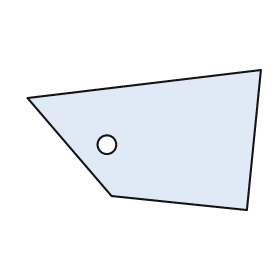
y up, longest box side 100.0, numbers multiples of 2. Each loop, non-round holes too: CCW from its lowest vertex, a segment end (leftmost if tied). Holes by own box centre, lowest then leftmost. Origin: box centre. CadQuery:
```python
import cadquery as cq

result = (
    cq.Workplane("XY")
    .moveTo(44.0, -30.0)
    .lineTo(50.0, 30.0)
    .lineTo(-50.0, 18.0)
    .lineTo(-14.0, -24.0)
    .close()
    .moveTo(-16.0, -2.0)
    .circle(4.0)
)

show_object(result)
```